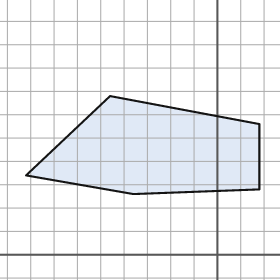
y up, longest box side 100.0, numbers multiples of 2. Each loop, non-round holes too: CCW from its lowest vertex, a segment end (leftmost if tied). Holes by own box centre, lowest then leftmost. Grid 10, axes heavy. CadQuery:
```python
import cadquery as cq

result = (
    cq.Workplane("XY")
    .moveTo(-36.0, 26.0)
    .lineTo(18.0, 28.0)
    .lineTo(18.0, 56.0)
    .lineTo(-46.0, 68.0)
    .lineTo(-82.0, 34.0)
    .close()
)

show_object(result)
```